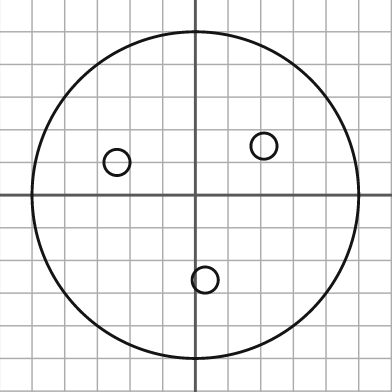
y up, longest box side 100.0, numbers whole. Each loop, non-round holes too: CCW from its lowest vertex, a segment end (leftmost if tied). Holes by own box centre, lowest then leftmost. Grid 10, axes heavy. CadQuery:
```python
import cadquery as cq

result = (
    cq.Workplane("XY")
    .moveTo(0.0, 0.0)
    .circle(50.0)
    .moveTo(3.0, -26.0)
    .circle(4.0)
    .moveTo(-24.0, 10.0)
    .circle(4.0)
    .moveTo(21.0, 15.0)
    .circle(4.0)
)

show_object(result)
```